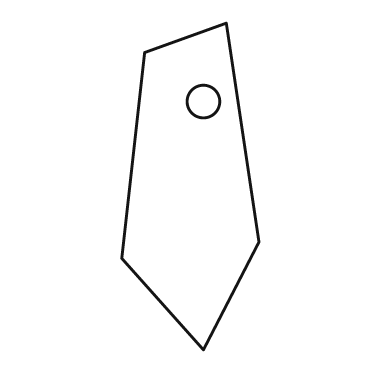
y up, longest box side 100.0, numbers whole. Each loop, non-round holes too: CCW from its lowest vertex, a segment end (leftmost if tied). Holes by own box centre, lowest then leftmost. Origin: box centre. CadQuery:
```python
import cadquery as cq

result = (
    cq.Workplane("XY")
    .moveTo(4.0, -50.0)
    .lineTo(21.0, -17.0)
    .lineTo(11.0, 50.0)
    .lineTo(-14.0, 41.0)
    .lineTo(-21.0, -22.0)
    .close()
    .moveTo(4.0, 26.0)
    .circle(5.0)
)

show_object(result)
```